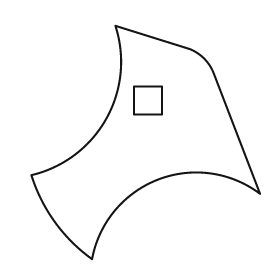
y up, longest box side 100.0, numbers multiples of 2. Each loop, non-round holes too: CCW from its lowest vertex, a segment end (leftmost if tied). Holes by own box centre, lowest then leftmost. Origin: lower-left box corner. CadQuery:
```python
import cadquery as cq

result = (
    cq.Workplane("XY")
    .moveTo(26.0, 0.0)
    .threePointArc((54.0, 34.0), (98.0, 28.0))
    .lineTo(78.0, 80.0)
    .threePointArc((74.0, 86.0), (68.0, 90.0))
    .lineTo(36.0, 100.0)
    .threePointArc((32.0, 60.0), (0.0, 36.0))
    .threePointArc((10.0, 16.0), (26.0, 0.0))
    .close()
    .moveTo(44.0, 62.0)
    .lineTo(56.0, 62.0)
    .lineTo(56.0, 74.0)
    .lineTo(44.0, 74.0)
    .close()
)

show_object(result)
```